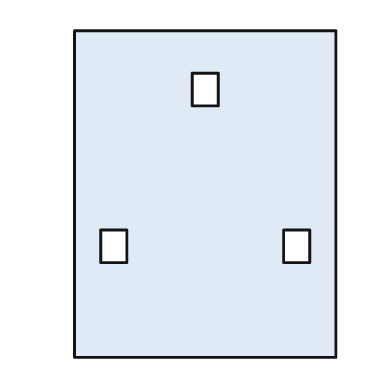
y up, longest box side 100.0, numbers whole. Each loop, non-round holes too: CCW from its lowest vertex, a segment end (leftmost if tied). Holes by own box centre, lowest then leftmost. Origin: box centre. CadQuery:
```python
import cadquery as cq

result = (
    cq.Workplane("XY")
    .moveTo(-40.0, -50.0)
    .lineTo(40.0, -50.0)
    .lineTo(40.0, 50.0)
    .lineTo(-40.0, 50.0)
    .close()
    .moveTo(-32.0, -21.0)
    .lineTo(-24.0, -21.0)
    .lineTo(-24.0, -11.0)
    .lineTo(-32.0, -11.0)
    .close()
    .moveTo(24.0, -21.0)
    .lineTo(32.0, -21.0)
    .lineTo(32.0, -11.0)
    .lineTo(24.0, -11.0)
    .close()
    .moveTo(-4.0, 27.0)
    .lineTo(4.0, 27.0)
    .lineTo(4.0, 37.0)
    .lineTo(-4.0, 37.0)
    .close()
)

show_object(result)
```